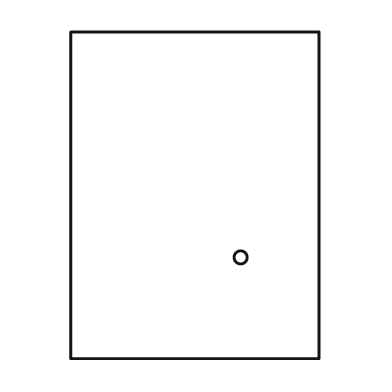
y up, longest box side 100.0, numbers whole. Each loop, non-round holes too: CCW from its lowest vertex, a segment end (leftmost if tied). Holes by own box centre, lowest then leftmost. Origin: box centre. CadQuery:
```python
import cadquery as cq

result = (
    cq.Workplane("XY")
    .moveTo(-38.0, -50.0)
    .lineTo(38.0, -50.0)
    .lineTo(38.0, 50.0)
    .lineTo(-38.0, 50.0)
    .close()
    .moveTo(14.0, -19.0)
    .circle(2.0)
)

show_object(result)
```